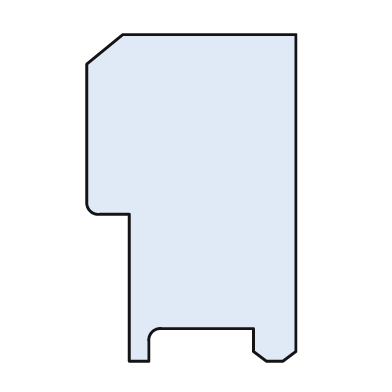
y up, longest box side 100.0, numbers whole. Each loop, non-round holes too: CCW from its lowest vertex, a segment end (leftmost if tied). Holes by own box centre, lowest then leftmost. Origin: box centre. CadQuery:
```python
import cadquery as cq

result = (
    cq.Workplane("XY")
    .moveTo(-19.0, -50.0)
    .lineTo(-13.0, -50.0)
    .lineTo(-13.0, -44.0)
    .threePointArc((-12.0, -41.0), (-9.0, -40.0))
    .lineTo(19.0, -40.0)
    .lineTo(19.0, -47.0)
    .lineTo(23.0, -50.0)
    .lineTo(28.0, -50.0)
    .lineTo(32.0, -47.0)
    .lineTo(32.0, 50.0)
    .lineTo(-21.0, 50.0)
    .lineTo(-32.0, 41.0)
    .lineTo(-32.0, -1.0)
    .threePointArc((-31.0, -4.0), (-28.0, -5.0))
    .lineTo(-19.0, -5.0)
    .close()
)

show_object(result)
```